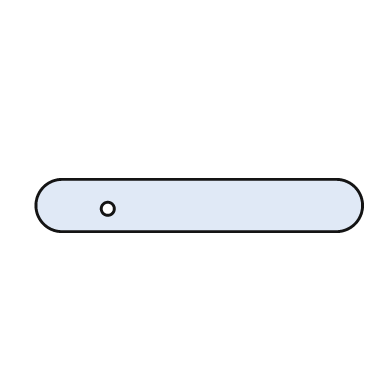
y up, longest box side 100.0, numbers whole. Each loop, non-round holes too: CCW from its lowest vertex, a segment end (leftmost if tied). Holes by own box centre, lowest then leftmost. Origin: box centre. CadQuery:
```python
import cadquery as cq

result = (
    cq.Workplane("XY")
    .moveTo(-42.0, -8.0)
    .lineTo(42.0, -8.0)
    .threePointArc((50.0, 0.0), (42.0, 8.0))
    .lineTo(-42.0, 8.0)
    .threePointArc((-50.0, 0.0), (-42.0, -8.0))
    .close()
    .moveTo(-28.0, -1.0)
    .circle(2.0)
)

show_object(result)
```